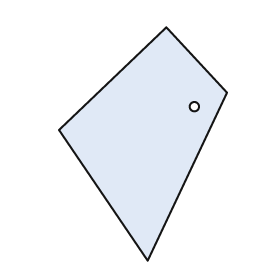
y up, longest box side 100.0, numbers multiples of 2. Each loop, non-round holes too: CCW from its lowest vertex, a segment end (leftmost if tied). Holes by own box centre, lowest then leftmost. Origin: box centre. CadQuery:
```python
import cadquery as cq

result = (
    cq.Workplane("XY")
    .moveTo(2.0, -50.0)
    .lineTo(36.0, 22.0)
    .lineTo(10.0, 50.0)
    .lineTo(-36.0, 6.0)
    .close()
    .moveTo(22.0, 16.0)
    .circle(2.0)
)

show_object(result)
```